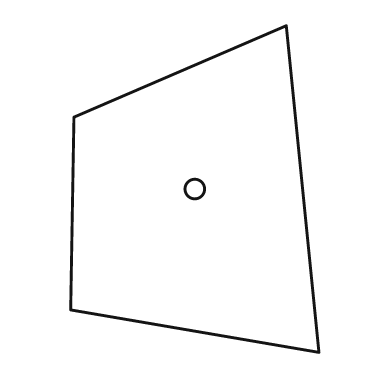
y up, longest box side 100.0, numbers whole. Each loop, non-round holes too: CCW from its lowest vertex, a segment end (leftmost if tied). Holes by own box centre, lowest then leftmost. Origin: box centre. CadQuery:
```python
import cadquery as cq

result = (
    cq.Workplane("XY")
    .moveTo(38.0, -50.0)
    .lineTo(28.0, 50.0)
    .lineTo(-37.0, 22.0)
    .lineTo(-38.0, -37.0)
    .close()
    .moveTo(0.0, 0.0)
    .circle(3.0)
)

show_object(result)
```